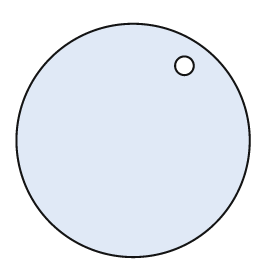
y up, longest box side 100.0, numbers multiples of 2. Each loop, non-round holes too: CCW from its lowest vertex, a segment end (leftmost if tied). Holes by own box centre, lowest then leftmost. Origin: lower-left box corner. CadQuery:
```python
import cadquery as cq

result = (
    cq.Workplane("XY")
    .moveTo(50.0, 50.0)
    .circle(50.0)
    .moveTo(72.0, 82.0)
    .circle(4.0)
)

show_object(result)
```